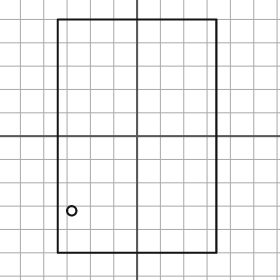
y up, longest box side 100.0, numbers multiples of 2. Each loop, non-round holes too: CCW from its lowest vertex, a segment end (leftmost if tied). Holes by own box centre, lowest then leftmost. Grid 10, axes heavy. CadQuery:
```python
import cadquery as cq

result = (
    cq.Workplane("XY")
    .moveTo(-34.0, -50.0)
    .lineTo(34.0, -50.0)
    .lineTo(34.0, 50.0)
    .lineTo(-34.0, 50.0)
    .close()
    .moveTo(-28.0, -32.0)
    .circle(2.0)
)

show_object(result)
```